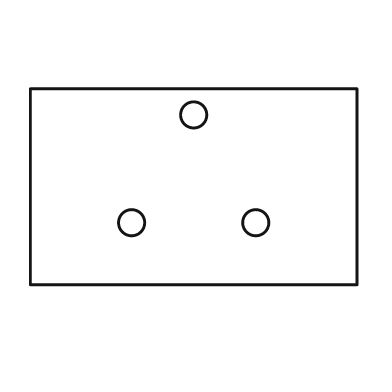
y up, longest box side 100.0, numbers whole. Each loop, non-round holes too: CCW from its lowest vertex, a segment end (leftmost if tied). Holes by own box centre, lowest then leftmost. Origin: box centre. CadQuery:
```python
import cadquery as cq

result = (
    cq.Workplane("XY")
    .moveTo(-50.0, -30.0)
    .lineTo(50.0, -30.0)
    .lineTo(50.0, 30.0)
    .lineTo(-50.0, 30.0)
    .close()
    .moveTo(-19.0, -11.0)
    .circle(4.0)
    .moveTo(19.0, -11.0)
    .circle(4.0)
    .moveTo(0.0, 22.0)
    .circle(4.0)
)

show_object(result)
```